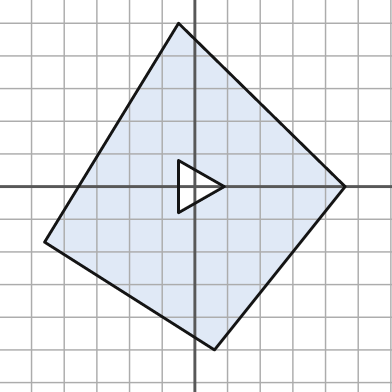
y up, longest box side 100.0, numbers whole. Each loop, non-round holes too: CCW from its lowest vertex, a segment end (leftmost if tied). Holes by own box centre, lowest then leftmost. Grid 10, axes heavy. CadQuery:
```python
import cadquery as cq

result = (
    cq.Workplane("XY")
    .moveTo(6.0, -50.0)
    .lineTo(46.0, 0.0)
    .lineTo(-5.0, 50.0)
    .lineTo(-46.0, -17.0)
    .close()
    .moveTo(-5.0, -8.0)
    .lineTo(9.0, 0.0)
    .lineTo(-5.0, 8.0)
    .close()
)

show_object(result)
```